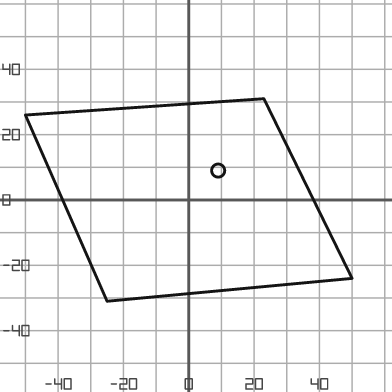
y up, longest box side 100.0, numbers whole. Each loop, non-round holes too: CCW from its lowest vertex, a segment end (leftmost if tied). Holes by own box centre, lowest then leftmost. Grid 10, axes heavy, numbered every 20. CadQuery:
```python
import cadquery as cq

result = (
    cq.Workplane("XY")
    .moveTo(-25.0, -31.0)
    .lineTo(50.0, -24.0)
    .lineTo(23.0, 31.0)
    .lineTo(-50.0, 26.0)
    .close()
    .moveTo(9.0, 9.0)
    .circle(2.0)
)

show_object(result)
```